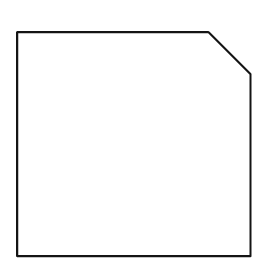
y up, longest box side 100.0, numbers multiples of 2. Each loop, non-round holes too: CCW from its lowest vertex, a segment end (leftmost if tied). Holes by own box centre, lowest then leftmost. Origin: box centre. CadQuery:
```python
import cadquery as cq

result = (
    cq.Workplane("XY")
    .moveTo(-50.0, -48.0)
    .lineTo(50.0, -48.0)
    .lineTo(50.0, 30.0)
    .lineTo(32.0, 48.0)
    .lineTo(-50.0, 48.0)
    .close()
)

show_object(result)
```